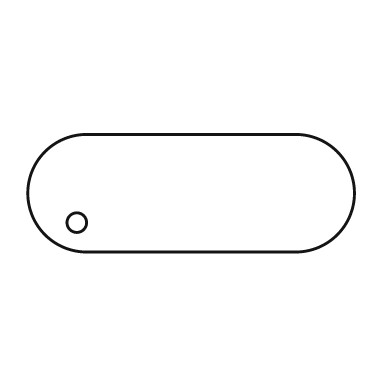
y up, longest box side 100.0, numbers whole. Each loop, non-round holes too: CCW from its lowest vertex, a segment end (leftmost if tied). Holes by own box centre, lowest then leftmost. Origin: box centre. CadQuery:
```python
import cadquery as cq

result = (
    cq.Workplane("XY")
    .moveTo(-32.0, -18.0)
    .lineTo(32.0, -18.0)
    .threePointArc((50.0, 0.0), (32.0, 18.0))
    .lineTo(-32.0, 18.0)
    .threePointArc((-50.0, 0.0), (-32.0, -18.0))
    .close()
    .moveTo(-35.0, -9.0)
    .circle(3.0)
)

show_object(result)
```